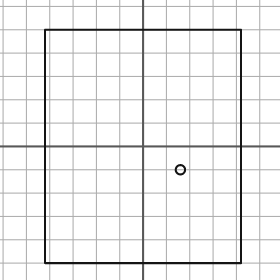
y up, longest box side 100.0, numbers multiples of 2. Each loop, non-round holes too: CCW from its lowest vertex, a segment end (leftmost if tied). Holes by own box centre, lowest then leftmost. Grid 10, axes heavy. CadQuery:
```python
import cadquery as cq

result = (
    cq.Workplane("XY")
    .moveTo(-42.0, -50.0)
    .lineTo(42.0, -50.0)
    .lineTo(42.0, 50.0)
    .lineTo(-42.0, 50.0)
    .close()
    .moveTo(16.0, -10.0)
    .circle(2.0)
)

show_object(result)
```